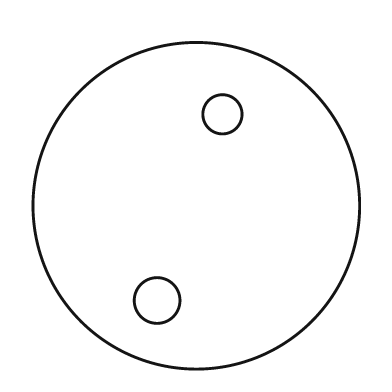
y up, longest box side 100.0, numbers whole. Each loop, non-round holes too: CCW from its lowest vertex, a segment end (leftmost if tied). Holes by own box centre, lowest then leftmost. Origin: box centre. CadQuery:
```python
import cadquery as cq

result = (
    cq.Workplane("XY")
    .moveTo(0.0, 0.0)
    .circle(50.0)
    .moveTo(-12.0, -29.0)
    .circle(7.0)
    .moveTo(8.0, 28.0)
    .circle(6.0)
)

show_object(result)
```